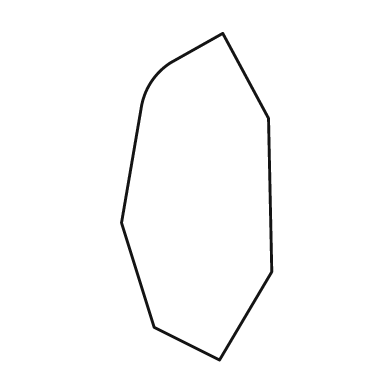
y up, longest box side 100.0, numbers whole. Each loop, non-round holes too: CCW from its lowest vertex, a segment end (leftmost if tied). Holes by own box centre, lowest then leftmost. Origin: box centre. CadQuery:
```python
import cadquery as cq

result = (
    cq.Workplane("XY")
    .moveTo(7.0, -50.0)
    .lineTo(23.0, -23.0)
    .lineTo(22.0, 24.0)
    .lineTo(8.0, 50.0)
    .lineTo(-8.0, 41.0)
    .threePointArc((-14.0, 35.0), (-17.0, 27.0))
    .lineTo(-23.0, -8.0)
    .lineTo(-13.0, -40.0)
    .close()
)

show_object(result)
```